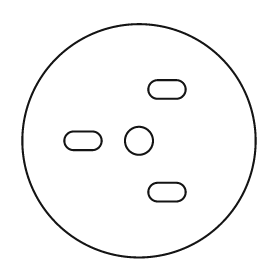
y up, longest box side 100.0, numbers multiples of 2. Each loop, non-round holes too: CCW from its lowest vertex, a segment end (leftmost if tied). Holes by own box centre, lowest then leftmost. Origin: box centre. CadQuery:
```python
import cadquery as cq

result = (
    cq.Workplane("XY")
    .moveTo(0.0, 0.0)
    .circle(50.0)
    .moveTo(8.0, -26.0)
    .lineTo(16.0, -26.0)
    .threePointArc((20.0, -22.0), (16.0, -18.0))
    .lineTo(8.0, -18.0)
    .threePointArc((4.0, -22.0), (8.0, -26.0))
    .close()
    .moveTo(-28.0, -4.0)
    .lineTo(-20.0, -4.0)
    .threePointArc((-16.0, 0.0), (-20.0, 4.0))
    .lineTo(-28.0, 4.0)
    .threePointArc((-32.0, 0.0), (-28.0, -4.0))
    .close()
    .moveTo(0.0, 0.0)
    .circle(6.0)
    .moveTo(8.0, 18.0)
    .lineTo(16.0, 18.0)
    .threePointArc((20.0, 22.0), (16.0, 26.0))
    .lineTo(8.0, 26.0)
    .threePointArc((4.0, 22.0), (8.0, 18.0))
    .close()
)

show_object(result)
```